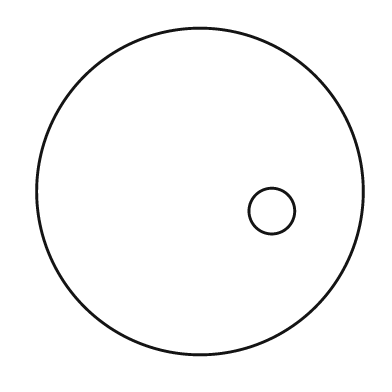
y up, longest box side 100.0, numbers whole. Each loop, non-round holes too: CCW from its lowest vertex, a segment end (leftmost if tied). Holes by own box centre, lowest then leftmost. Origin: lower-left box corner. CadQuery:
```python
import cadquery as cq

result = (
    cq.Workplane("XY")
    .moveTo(50.0, 50.0)
    .circle(50.0)
    .moveTo(72.0, 44.0)
    .circle(7.0)
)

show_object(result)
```